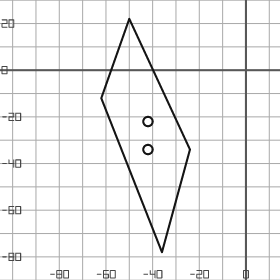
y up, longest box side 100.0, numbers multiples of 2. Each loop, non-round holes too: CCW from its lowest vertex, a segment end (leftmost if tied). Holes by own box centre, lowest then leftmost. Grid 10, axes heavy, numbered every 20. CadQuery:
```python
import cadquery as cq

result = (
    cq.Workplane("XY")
    .moveTo(-36.0, -78.0)
    .lineTo(-24.0, -34.0)
    .lineTo(-50.0, 22.0)
    .lineTo(-62.0, -12.0)
    .close()
    .moveTo(-42.0, -34.0)
    .circle(2.0)
    .moveTo(-42.0, -22.0)
    .circle(2.0)
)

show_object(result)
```